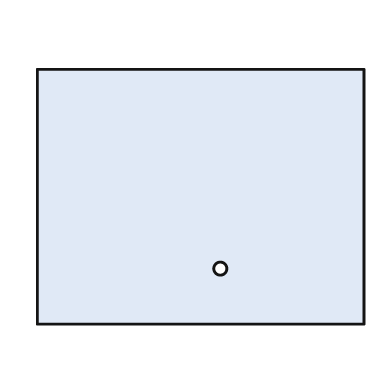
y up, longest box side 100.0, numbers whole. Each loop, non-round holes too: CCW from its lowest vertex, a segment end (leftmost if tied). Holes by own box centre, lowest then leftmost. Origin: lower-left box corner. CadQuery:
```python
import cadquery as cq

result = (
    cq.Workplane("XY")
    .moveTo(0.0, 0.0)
    .lineTo(100.0, 0.0)
    .lineTo(100.0, 78.0)
    .lineTo(0.0, 78.0)
    .close()
    .moveTo(56.0, 17.0)
    .circle(2.0)
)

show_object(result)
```